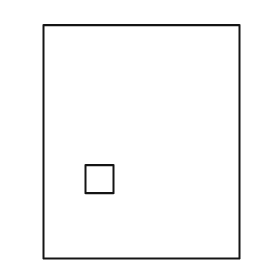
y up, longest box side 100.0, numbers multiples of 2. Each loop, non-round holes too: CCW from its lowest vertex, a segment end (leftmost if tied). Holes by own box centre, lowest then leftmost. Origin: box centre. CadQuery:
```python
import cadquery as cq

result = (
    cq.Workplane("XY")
    .moveTo(-42.0, -50.0)
    .lineTo(42.0, -50.0)
    .lineTo(42.0, 50.0)
    .lineTo(-42.0, 50.0)
    .close()
    .moveTo(-24.0, -22.0)
    .lineTo(-12.0, -22.0)
    .lineTo(-12.0, -10.0)
    .lineTo(-24.0, -10.0)
    .close()
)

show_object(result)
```